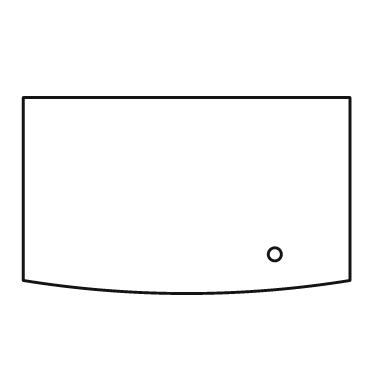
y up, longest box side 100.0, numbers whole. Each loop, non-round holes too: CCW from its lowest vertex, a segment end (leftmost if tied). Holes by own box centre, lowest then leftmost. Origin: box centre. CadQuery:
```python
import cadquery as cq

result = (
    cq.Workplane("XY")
    .moveTo(-50.0, -26.0)
    .threePointArc((0.0, -30.0), (50.0, -26.0))
    .lineTo(50.0, 30.0)
    .lineTo(-50.0, 30.0)
    .close()
    .moveTo(27.0, -18.0)
    .circle(2.0)
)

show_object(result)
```